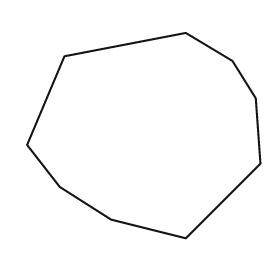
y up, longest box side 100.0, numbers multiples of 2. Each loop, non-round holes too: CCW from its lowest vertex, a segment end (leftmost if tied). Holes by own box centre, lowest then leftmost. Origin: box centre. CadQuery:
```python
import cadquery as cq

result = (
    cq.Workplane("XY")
    .moveTo(18.0, -44.0)
    .lineTo(50.0, -12.0)
    .lineTo(48.0, 16.0)
    .lineTo(38.0, 32.0)
    .lineTo(18.0, 44.0)
    .lineTo(-34.0, 34.0)
    .lineTo(-50.0, -4.0)
    .lineTo(-36.0, -22.0)
    .lineTo(-14.0, -36.0)
    .close()
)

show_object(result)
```